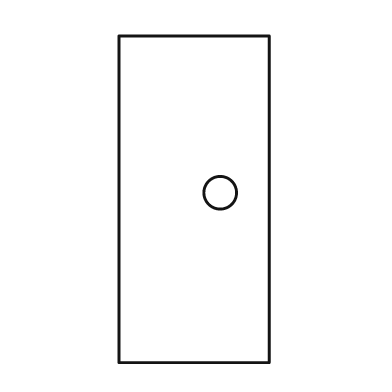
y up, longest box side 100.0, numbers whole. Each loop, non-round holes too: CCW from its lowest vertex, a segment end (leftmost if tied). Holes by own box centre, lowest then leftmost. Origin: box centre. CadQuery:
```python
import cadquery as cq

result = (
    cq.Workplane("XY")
    .moveTo(-23.0, -50.0)
    .lineTo(23.0, -50.0)
    .lineTo(23.0, 50.0)
    .lineTo(-23.0, 50.0)
    .close()
    .moveTo(8.0, 2.0)
    .circle(5.0)
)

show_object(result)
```